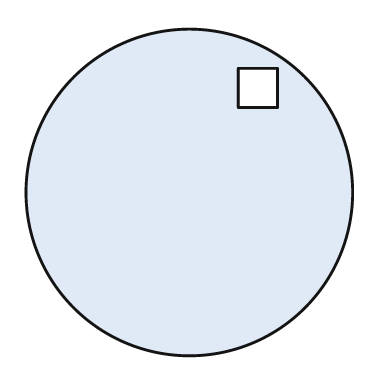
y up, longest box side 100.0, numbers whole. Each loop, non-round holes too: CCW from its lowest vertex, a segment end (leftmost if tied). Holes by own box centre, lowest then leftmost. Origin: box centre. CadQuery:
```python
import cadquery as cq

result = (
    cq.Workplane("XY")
    .moveTo(0.0, 0.0)
    .circle(50.0)
    .moveTo(15.0, 26.0)
    .lineTo(27.0, 26.0)
    .lineTo(27.0, 38.0)
    .lineTo(15.0, 38.0)
    .close()
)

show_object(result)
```